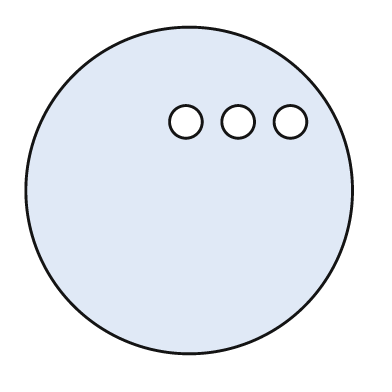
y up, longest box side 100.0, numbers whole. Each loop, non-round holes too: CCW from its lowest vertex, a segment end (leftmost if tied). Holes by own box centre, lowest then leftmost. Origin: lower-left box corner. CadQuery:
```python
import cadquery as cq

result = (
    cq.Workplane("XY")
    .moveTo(50.0, 50.0)
    .circle(50.0)
    .moveTo(49.0, 71.0)
    .circle(5.0)
    .moveTo(65.0, 71.0)
    .circle(5.0)
    .moveTo(81.0, 71.0)
    .circle(5.0)
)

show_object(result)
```